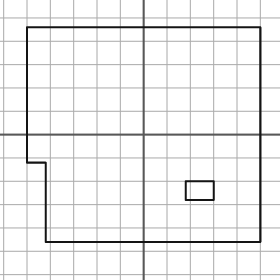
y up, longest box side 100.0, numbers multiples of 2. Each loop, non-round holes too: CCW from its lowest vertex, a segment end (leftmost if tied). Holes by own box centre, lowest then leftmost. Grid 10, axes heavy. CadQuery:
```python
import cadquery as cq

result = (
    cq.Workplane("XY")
    .moveTo(-42.0, -46.0)
    .lineTo(50.0, -46.0)
    .lineTo(50.0, 46.0)
    .lineTo(-50.0, 46.0)
    .lineTo(-50.0, -12.0)
    .lineTo(-42.0, -12.0)
    .close()
    .moveTo(18.0, -28.0)
    .lineTo(30.0, -28.0)
    .lineTo(30.0, -20.0)
    .lineTo(18.0, -20.0)
    .close()
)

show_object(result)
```